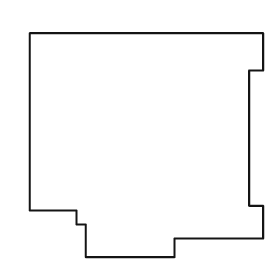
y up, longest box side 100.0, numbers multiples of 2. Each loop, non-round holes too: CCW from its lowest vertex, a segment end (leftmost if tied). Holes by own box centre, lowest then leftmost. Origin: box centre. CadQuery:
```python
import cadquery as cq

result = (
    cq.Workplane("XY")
    .moveTo(-26.0, -48.0)
    .lineTo(12.0, -48.0)
    .lineTo(12.0, -40.0)
    .lineTo(50.0, -40.0)
    .lineTo(50.0, -26.0)
    .lineTo(44.0, -26.0)
    .lineTo(44.0, 32.0)
    .lineTo(50.0, 32.0)
    .lineTo(50.0, 48.0)
    .lineTo(-50.0, 48.0)
    .lineTo(-50.0, -28.0)
    .lineTo(-30.0, -28.0)
    .lineTo(-30.0, -34.0)
    .lineTo(-26.0, -34.0)
    .close()
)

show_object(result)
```